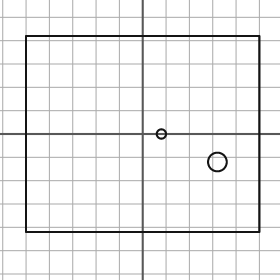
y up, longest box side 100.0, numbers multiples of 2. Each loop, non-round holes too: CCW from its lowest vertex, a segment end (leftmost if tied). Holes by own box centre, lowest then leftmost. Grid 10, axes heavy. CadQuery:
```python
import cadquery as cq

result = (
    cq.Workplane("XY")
    .moveTo(-50.0, -42.0)
    .lineTo(50.0, -42.0)
    .lineTo(50.0, 42.0)
    .lineTo(-50.0, 42.0)
    .close()
    .moveTo(32.0, -12.0)
    .circle(4.0)
    .moveTo(8.0, 0.0)
    .circle(2.0)
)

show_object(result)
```